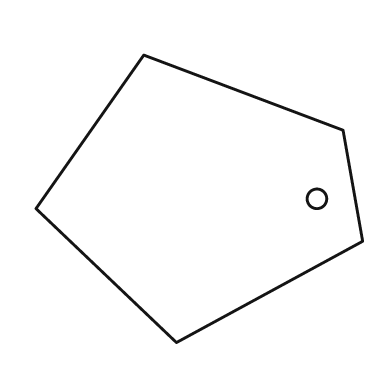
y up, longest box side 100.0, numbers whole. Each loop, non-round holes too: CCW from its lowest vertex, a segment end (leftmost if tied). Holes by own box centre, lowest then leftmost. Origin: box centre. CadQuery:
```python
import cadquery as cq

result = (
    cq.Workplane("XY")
    .moveTo(-7.0, -44.0)
    .lineTo(50.0, -13.0)
    .lineTo(44.0, 21.0)
    .lineTo(-17.0, 44.0)
    .lineTo(-50.0, -3.0)
    .close()
    .moveTo(36.0, 0.0)
    .circle(3.0)
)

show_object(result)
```